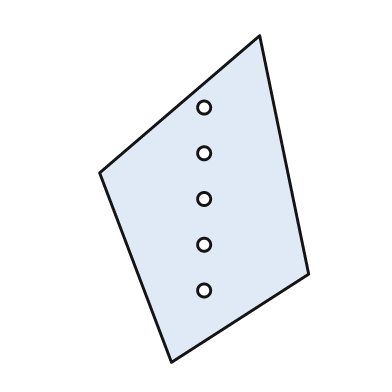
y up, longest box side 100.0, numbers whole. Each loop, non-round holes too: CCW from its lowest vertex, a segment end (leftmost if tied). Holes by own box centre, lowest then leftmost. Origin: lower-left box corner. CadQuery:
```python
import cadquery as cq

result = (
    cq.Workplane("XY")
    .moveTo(22.0, 0.0)
    .lineTo(64.0, 27.0)
    .lineTo(49.0, 100.0)
    .lineTo(0.0, 58.0)
    .close()
    .moveTo(32.0, 22.0)
    .circle(2.0)
    .moveTo(32.0, 36.0)
    .circle(2.0)
    .moveTo(32.0, 50.0)
    .circle(2.0)
    .moveTo(32.0, 64.0)
    .circle(2.0)
    .moveTo(32.0, 78.0)
    .circle(2.0)
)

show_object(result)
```